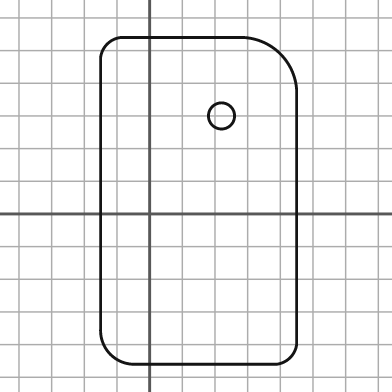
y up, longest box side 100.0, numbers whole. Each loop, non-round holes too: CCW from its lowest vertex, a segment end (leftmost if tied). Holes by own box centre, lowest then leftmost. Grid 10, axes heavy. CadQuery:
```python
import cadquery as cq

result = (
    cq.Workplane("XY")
    .moveTo(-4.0, -46.0)
    .lineTo(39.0, -46.0)
    .threePointArc((43.0, -44.0), (45.0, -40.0))
    .lineTo(45.0, 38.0)
    .threePointArc((40.0, 49.0), (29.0, 54.0))
    .lineTo(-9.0, 54.0)
    .threePointArc((-13.0, 52.0), (-15.0, 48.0))
    .lineTo(-15.0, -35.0)
    .threePointArc((-12.0, -43.0), (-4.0, -46.0))
    .close()
    .moveTo(22.0, 30.0)
    .circle(4.0)
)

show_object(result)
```